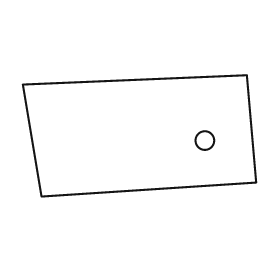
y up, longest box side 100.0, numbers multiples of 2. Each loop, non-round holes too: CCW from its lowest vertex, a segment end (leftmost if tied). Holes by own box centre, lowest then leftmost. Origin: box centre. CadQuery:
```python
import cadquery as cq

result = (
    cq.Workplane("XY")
    .moveTo(-42.0, -26.0)
    .lineTo(50.0, -20.0)
    .lineTo(46.0, 26.0)
    .lineTo(-50.0, 22.0)
    .close()
    .moveTo(28.0, -2.0)
    .circle(4.0)
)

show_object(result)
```